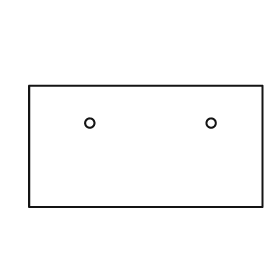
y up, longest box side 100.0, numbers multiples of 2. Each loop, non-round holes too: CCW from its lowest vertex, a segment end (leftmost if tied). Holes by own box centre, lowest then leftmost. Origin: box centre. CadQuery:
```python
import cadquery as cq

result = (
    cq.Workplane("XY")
    .moveTo(-50.0, -26.0)
    .lineTo(50.0, -26.0)
    .lineTo(50.0, 26.0)
    .lineTo(-50.0, 26.0)
    .close()
    .moveTo(-24.0, 10.0)
    .circle(2.0)
    .moveTo(28.0, 10.0)
    .circle(2.0)
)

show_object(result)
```